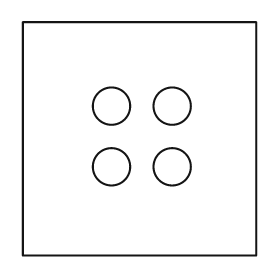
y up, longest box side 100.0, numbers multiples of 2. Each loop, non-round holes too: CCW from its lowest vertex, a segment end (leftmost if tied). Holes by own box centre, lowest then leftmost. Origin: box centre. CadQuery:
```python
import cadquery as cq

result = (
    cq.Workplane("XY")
    .moveTo(-50.0, -50.0)
    .lineTo(50.0, -50.0)
    .lineTo(50.0, 50.0)
    .lineTo(-50.0, 50.0)
    .close()
    .moveTo(-12.0, -12.0)
    .circle(8.0)
    .moveTo(14.0, -12.0)
    .circle(8.0)
    .moveTo(-12.0, 14.0)
    .circle(8.0)
    .moveTo(14.0, 14.0)
    .circle(8.0)
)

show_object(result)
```